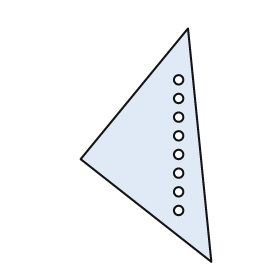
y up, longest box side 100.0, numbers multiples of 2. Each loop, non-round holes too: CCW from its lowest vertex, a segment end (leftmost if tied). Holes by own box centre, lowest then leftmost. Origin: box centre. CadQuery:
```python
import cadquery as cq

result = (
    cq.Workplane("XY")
    .moveTo(28.0, -50.0)
    .lineTo(18.0, 50.0)
    .lineTo(-28.0, -6.0)
    .close()
    .moveTo(14.0, -28.0)
    .circle(2.0)
    .moveTo(14.0, -20.0)
    .circle(2.0)
    .moveTo(14.0, -12.0)
    .circle(2.0)
    .moveTo(14.0, -4.0)
    .circle(2.0)
    .moveTo(14.0, 4.0)
    .circle(2.0)
    .moveTo(14.0, 12.0)
    .circle(2.0)
    .moveTo(14.0, 20.0)
    .circle(2.0)
    .moveTo(14.0, 28.0)
    .circle(2.0)
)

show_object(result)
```